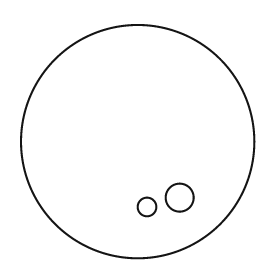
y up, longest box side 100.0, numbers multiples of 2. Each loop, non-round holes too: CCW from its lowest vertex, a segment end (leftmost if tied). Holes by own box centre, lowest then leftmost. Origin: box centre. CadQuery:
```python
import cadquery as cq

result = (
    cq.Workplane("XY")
    .moveTo(0.0, 0.0)
    .circle(50.0)
    .moveTo(4.0, -28.0)
    .circle(4.0)
    .moveTo(18.0, -24.0)
    .circle(6.0)
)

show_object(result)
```